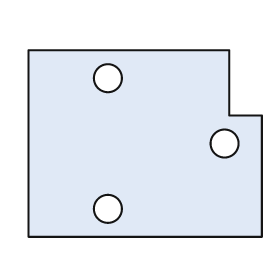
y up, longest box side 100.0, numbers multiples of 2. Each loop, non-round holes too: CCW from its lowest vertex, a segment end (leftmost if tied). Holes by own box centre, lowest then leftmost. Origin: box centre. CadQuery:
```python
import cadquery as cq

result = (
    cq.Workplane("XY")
    .moveTo(-50.0, -40.0)
    .lineTo(50.0, -40.0)
    .lineTo(50.0, 12.0)
    .lineTo(36.0, 12.0)
    .lineTo(36.0, 40.0)
    .lineTo(-50.0, 40.0)
    .close()
    .moveTo(-16.0, -28.0)
    .circle(6.0)
    .moveTo(34.0, 0.0)
    .circle(6.0)
    .moveTo(-16.0, 28.0)
    .circle(6.0)
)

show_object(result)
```